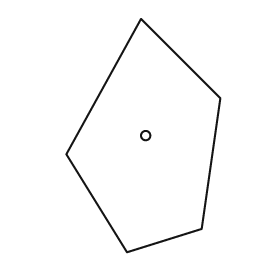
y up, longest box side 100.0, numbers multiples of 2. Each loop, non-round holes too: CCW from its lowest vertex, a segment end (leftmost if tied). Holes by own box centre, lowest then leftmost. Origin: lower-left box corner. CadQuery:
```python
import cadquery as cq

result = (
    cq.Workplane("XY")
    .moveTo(26.0, 0.0)
    .lineTo(58.0, 10.0)
    .lineTo(66.0, 66.0)
    .lineTo(32.0, 100.0)
    .lineTo(0.0, 42.0)
    .close()
    .moveTo(34.0, 50.0)
    .circle(2.0)
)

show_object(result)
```